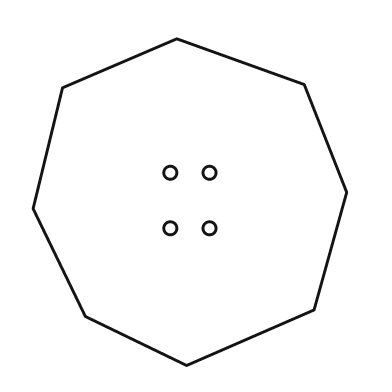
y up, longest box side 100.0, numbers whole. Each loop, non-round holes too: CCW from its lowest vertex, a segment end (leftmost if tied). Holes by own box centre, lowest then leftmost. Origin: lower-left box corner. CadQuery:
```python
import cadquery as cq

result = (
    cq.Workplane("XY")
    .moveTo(47.0, 0.0)
    .lineTo(86.0, 17.0)
    .lineTo(96.0, 53.0)
    .lineTo(83.0, 86.0)
    .lineTo(44.0, 100.0)
    .lineTo(9.0, 85.0)
    .lineTo(0.0, 48.0)
    .lineTo(16.0, 15.0)
    .close()
    .moveTo(42.0, 42.0)
    .circle(2.0)
    .moveTo(54.0, 42.0)
    .circle(2.0)
    .moveTo(42.0, 59.0)
    .circle(2.0)
    .moveTo(54.0, 59.0)
    .circle(2.0)
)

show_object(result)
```